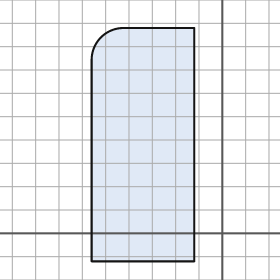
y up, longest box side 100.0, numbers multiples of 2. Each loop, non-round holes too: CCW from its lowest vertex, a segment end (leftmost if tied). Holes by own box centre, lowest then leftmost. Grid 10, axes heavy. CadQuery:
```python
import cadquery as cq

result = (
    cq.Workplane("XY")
    .moveTo(-56.0, -12.0)
    .lineTo(-12.0, -12.0)
    .lineTo(-12.0, 88.0)
    .lineTo(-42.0, 88.0)
    .threePointArc((-52.0, 84.0), (-56.0, 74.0))
    .close()
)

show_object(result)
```